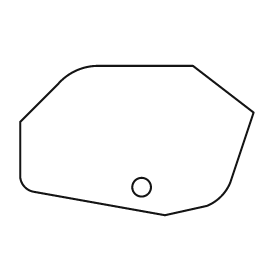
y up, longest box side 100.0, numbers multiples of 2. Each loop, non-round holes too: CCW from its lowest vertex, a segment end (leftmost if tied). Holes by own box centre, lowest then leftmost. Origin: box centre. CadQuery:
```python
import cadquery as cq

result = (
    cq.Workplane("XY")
    .moveTo(12.0, -32.0)
    .lineTo(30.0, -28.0)
    .threePointArc((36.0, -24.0), (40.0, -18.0))
    .lineTo(50.0, 12.0)
    .lineTo(24.0, 32.0)
    .lineTo(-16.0, 32.0)
    .threePointArc((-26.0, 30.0), (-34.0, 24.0))
    .lineTo(-50.0, 8.0)
    .lineTo(-50.0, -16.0)
    .threePointArc((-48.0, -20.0), (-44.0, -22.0))
    .close()
    .moveTo(2.0, -20.0)
    .circle(4.0)
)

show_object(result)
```